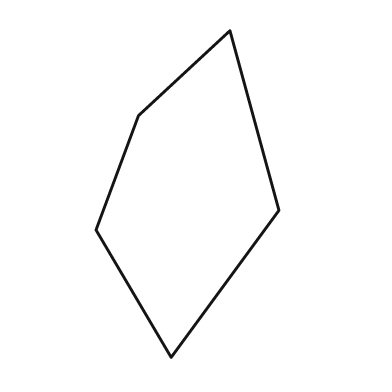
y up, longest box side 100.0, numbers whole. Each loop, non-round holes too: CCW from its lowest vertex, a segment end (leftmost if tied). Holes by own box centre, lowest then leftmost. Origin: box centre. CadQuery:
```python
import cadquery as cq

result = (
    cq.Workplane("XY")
    .moveTo(-5.0, -50.0)
    .lineTo(28.0, -5.0)
    .lineTo(13.0, 50.0)
    .lineTo(-15.0, 24.0)
    .lineTo(-28.0, -11.0)
    .close()
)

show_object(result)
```